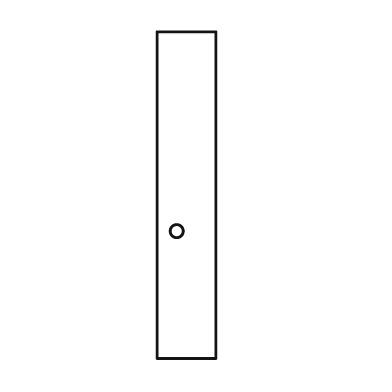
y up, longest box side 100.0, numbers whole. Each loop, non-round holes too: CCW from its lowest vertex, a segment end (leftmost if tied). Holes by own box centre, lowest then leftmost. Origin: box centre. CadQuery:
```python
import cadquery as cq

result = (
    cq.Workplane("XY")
    .moveTo(-9.0, -50.0)
    .lineTo(9.0, -50.0)
    .lineTo(9.0, 50.0)
    .lineTo(-9.0, 50.0)
    .close()
    .moveTo(-3.0, -11.0)
    .circle(2.0)
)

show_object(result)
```